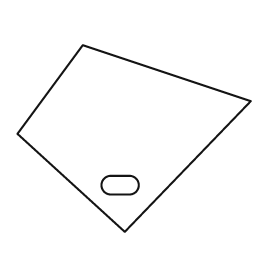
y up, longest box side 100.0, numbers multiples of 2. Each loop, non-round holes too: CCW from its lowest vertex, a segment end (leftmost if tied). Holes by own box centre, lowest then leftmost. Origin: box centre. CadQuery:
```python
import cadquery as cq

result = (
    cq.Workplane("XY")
    .moveTo(-4.0, -40.0)
    .lineTo(50.0, 16.0)
    .lineTo(-22.0, 40.0)
    .lineTo(-50.0, 2.0)
    .close()
    .moveTo(-10.0, -24.0)
    .lineTo(-2.0, -24.0)
    .threePointArc((2.0, -20.0), (-2.0, -16.0))
    .lineTo(-10.0, -16.0)
    .threePointArc((-14.0, -20.0), (-10.0, -24.0))
    .close()
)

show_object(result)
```